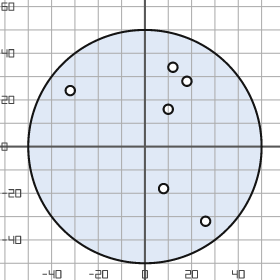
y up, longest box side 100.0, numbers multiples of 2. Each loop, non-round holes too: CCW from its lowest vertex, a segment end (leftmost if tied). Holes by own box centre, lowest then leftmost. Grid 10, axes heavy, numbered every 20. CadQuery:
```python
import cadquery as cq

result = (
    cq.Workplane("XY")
    .moveTo(0.0, 0.0)
    .circle(50.0)
    .moveTo(26.0, -32.0)
    .circle(2.0)
    .moveTo(8.0, -18.0)
    .circle(2.0)
    .moveTo(10.0, 16.0)
    .circle(2.0)
    .moveTo(-32.0, 24.0)
    .circle(2.0)
    .moveTo(18.0, 28.0)
    .circle(2.0)
    .moveTo(12.0, 34.0)
    .circle(2.0)
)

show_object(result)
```